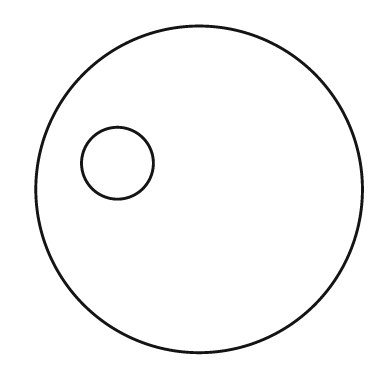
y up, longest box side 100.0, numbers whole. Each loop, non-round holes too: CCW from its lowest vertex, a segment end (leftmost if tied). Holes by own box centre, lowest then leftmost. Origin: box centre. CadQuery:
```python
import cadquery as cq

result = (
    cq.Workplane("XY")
    .moveTo(0.0, 0.0)
    .circle(50.0)
    .moveTo(-25.0, 8.0)
    .circle(11.0)
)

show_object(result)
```